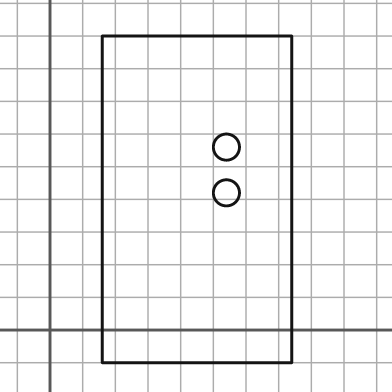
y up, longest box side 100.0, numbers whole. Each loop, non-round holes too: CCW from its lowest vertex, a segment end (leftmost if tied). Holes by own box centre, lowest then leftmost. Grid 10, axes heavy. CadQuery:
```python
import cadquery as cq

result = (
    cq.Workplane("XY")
    .moveTo(16.0, -10.0)
    .lineTo(74.0, -10.0)
    .lineTo(74.0, 90.0)
    .lineTo(16.0, 90.0)
    .close()
    .moveTo(54.0, 42.0)
    .circle(4.0)
    .moveTo(54.0, 56.0)
    .circle(4.0)
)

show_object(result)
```